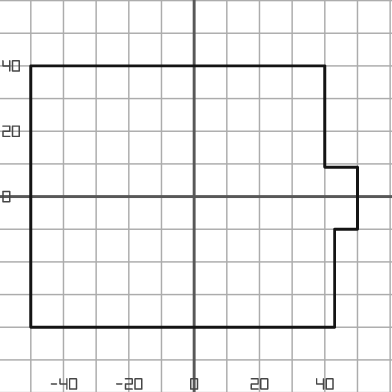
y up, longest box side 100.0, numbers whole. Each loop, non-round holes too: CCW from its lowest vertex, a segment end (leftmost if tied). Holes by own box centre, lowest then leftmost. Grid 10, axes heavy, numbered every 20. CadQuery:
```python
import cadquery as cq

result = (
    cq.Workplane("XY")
    .moveTo(-50.0, -40.0)
    .lineTo(43.0, -40.0)
    .lineTo(43.0, -10.0)
    .lineTo(50.0, -10.0)
    .lineTo(50.0, 9.0)
    .lineTo(40.0, 9.0)
    .lineTo(40.0, 40.0)
    .lineTo(-50.0, 40.0)
    .close()
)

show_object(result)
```